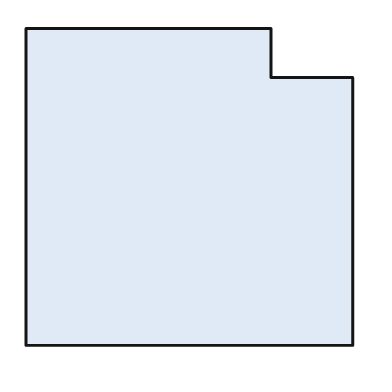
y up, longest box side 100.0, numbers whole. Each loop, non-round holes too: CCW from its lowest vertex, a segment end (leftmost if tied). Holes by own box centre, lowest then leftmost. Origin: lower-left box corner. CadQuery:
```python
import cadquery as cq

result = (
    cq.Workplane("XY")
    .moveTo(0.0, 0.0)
    .lineTo(100.0, 0.0)
    .lineTo(100.0, 82.0)
    .lineTo(75.0, 82.0)
    .lineTo(75.0, 97.0)
    .lineTo(0.0, 97.0)
    .close()
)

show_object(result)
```